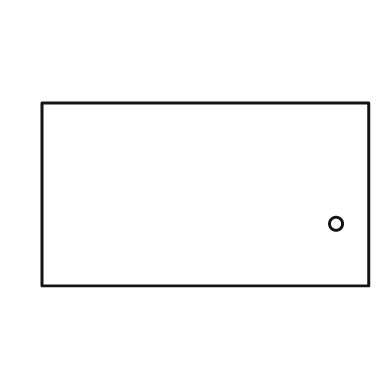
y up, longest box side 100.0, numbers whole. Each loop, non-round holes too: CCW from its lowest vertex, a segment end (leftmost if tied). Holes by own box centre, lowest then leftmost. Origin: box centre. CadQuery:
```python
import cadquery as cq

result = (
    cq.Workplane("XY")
    .moveTo(-50.0, -28.0)
    .lineTo(50.0, -28.0)
    .lineTo(50.0, 28.0)
    .lineTo(-50.0, 28.0)
    .close()
    .moveTo(40.0, -9.0)
    .circle(2.0)
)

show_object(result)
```